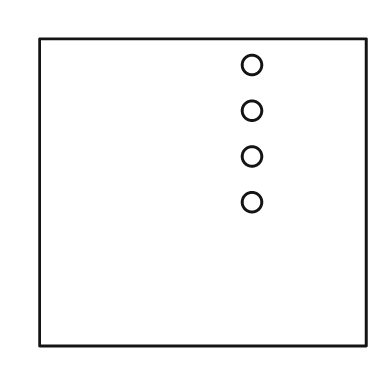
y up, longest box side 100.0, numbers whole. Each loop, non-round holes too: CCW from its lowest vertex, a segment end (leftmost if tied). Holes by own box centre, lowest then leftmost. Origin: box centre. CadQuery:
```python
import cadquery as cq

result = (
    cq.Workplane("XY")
    .moveTo(-50.0, -47.0)
    .lineTo(50.0, -47.0)
    .lineTo(50.0, 47.0)
    .lineTo(-50.0, 47.0)
    .close()
    .moveTo(15.0, -3.0)
    .circle(3.0)
    .moveTo(15.0, 11.0)
    .circle(3.0)
    .moveTo(15.0, 25.0)
    .circle(3.0)
    .moveTo(15.0, 39.0)
    .circle(3.0)
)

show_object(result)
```